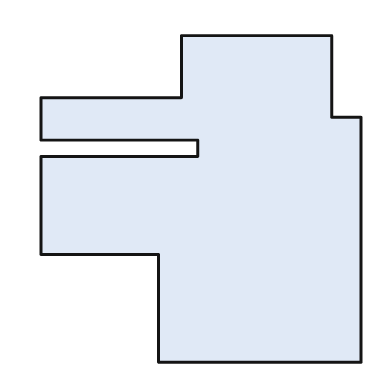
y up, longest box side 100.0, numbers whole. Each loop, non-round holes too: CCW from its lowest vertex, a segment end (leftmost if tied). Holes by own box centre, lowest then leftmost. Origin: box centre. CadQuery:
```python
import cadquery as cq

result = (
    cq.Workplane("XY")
    .moveTo(-13.0, -50.0)
    .lineTo(49.0, -50.0)
    .lineTo(49.0, 25.0)
    .lineTo(40.0, 25.0)
    .lineTo(40.0, 50.0)
    .lineTo(-6.0, 50.0)
    .lineTo(-6.0, 31.0)
    .lineTo(-49.0, 31.0)
    .lineTo(-49.0, 18.0)
    .lineTo(-1.0, 18.0)
    .lineTo(-1.0, 13.0)
    .lineTo(-49.0, 13.0)
    .lineTo(-49.0, -17.0)
    .lineTo(-13.0, -17.0)
    .close()
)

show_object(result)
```